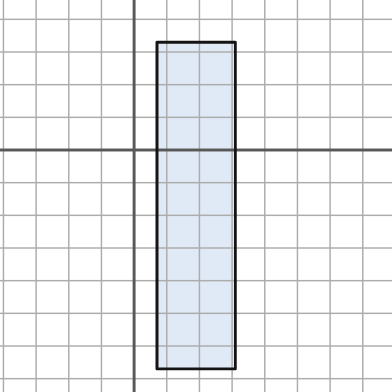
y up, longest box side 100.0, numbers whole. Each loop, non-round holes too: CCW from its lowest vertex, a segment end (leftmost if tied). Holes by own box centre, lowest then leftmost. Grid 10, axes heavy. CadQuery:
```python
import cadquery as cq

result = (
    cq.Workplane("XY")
    .moveTo(7.0, -67.0)
    .lineTo(31.0, -67.0)
    .lineTo(31.0, 33.0)
    .lineTo(7.0, 33.0)
    .close()
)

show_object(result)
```